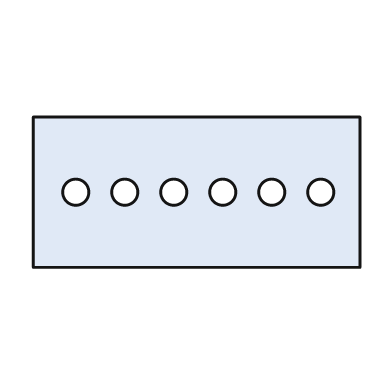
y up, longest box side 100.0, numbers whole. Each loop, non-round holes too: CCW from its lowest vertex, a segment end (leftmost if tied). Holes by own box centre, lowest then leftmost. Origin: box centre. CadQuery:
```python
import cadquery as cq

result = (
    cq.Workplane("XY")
    .moveTo(-50.0, -23.0)
    .lineTo(50.0, -23.0)
    .lineTo(50.0, 23.0)
    .lineTo(-50.0, 23.0)
    .close()
    .moveTo(-37.0, 0.0)
    .circle(4.0)
    .moveTo(-22.0, 0.0)
    .circle(4.0)
    .moveTo(-7.0, 0.0)
    .circle(4.0)
    .moveTo(8.0, 0.0)
    .circle(4.0)
    .moveTo(23.0, 0.0)
    .circle(4.0)
    .moveTo(38.0, 0.0)
    .circle(4.0)
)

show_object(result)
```